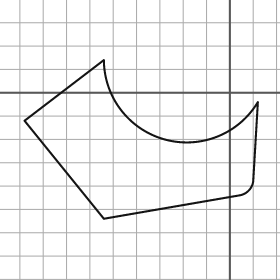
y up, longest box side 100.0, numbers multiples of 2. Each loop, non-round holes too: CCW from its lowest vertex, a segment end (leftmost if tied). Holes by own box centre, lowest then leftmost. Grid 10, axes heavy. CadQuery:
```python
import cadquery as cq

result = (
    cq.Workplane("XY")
    .moveTo(-54.0, -54.0)
    .lineTo(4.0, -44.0)
    .threePointArc((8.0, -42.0), (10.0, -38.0))
    .lineTo(12.0, -4.0)
    .threePointArc((-28.0, -20.0), (-54.0, 14.0))
    .lineTo(-88.0, -12.0)
    .close()
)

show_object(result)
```